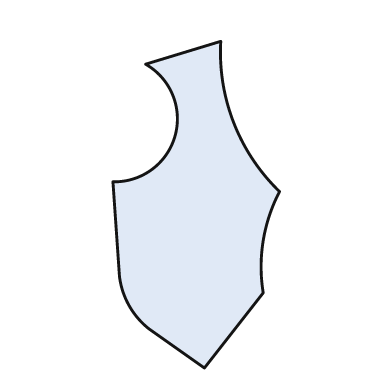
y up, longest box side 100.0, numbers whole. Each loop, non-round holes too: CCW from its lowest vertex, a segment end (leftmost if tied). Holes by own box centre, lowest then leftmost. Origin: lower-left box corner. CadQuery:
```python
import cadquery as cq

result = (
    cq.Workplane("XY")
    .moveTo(28.0, 0.0)
    .lineTo(46.0, 23.0)
    .threePointArc((46.0, 39.0), (51.0, 54.0))
    .threePointArc((37.0, 75.0), (33.0, 100.0))
    .lineTo(10.0, 93.0)
    .threePointArc((19.0, 71.0), (0.0, 57.0))
    .lineTo(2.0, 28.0)
    .threePointArc((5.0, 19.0), (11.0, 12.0))
    .close()
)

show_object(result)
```